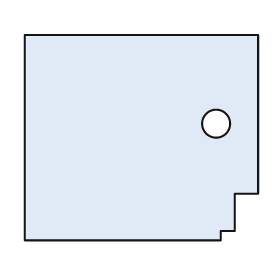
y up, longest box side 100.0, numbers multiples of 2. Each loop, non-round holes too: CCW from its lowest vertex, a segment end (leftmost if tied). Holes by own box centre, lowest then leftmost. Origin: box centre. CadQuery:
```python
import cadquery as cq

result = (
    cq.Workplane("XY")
    .moveTo(-50.0, -44.0)
    .lineTo(34.0, -44.0)
    .lineTo(34.0, -40.0)
    .lineTo(40.0, -40.0)
    .lineTo(40.0, -24.0)
    .lineTo(50.0, -24.0)
    .lineTo(50.0, 44.0)
    .lineTo(-50.0, 44.0)
    .close()
    .moveTo(32.0, 6.0)
    .circle(6.0)
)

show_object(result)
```